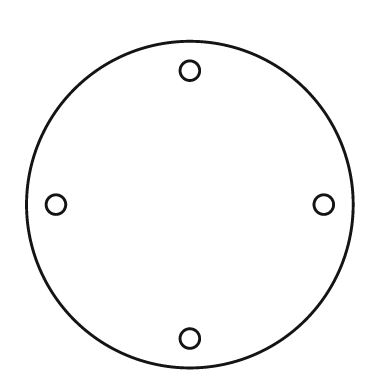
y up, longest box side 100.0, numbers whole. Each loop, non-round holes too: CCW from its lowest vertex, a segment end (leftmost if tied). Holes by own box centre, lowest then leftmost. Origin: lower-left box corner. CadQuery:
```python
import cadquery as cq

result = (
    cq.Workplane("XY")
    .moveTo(50.0, 50.0)
    .circle(50.0)
    .moveTo(50.0, 9.0)
    .circle(3.0)
    .moveTo(9.0, 50.0)
    .circle(3.0)
    .moveTo(91.0, 50.0)
    .circle(3.0)
    .moveTo(50.0, 91.0)
    .circle(3.0)
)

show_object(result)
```